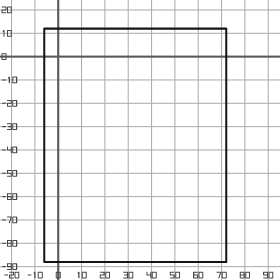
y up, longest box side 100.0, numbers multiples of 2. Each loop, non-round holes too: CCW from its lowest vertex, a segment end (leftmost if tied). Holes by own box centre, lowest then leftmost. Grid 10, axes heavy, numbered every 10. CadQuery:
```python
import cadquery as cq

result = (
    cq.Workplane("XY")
    .moveTo(-6.0, -88.0)
    .lineTo(72.0, -88.0)
    .lineTo(72.0, 12.0)
    .lineTo(-6.0, 12.0)
    .close()
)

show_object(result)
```